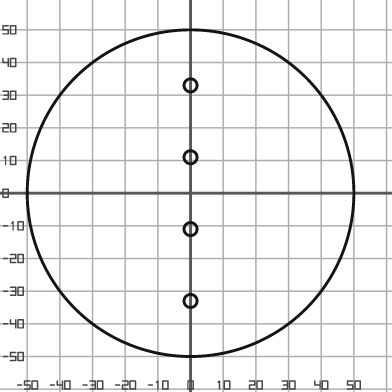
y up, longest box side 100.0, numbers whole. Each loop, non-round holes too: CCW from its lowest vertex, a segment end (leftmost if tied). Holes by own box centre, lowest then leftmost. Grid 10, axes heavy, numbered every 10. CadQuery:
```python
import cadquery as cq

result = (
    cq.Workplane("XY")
    .moveTo(0.0, 0.0)
    .circle(50.0)
    .moveTo(0.0, -33.0)
    .circle(2.0)
    .moveTo(0.0, -11.0)
    .circle(2.0)
    .moveTo(0.0, 11.0)
    .circle(2.0)
    .moveTo(0.0, 33.0)
    .circle(2.0)
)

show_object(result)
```